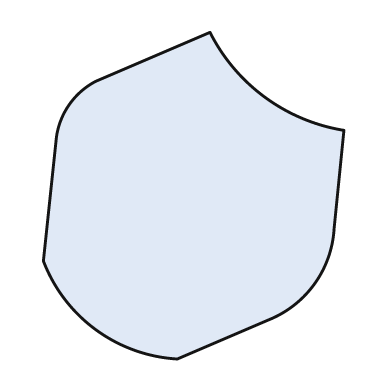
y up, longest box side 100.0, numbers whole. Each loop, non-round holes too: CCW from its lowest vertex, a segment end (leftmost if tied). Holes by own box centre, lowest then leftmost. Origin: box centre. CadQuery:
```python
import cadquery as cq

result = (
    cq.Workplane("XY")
    .moveTo(-5.0, -50.0)
    .lineTo(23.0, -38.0)
    .threePointArc((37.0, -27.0), (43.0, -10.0))
    .lineTo(46.0, 20.0)
    .threePointArc((22.0, 30.0), (5.0, 50.0))
    .lineTo(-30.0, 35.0)
    .threePointArc((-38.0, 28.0), (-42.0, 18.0))
    .lineTo(-46.0, -20.0)
    .threePointArc((-30.0, -41.0), (-5.0, -50.0))
    .close()
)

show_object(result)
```